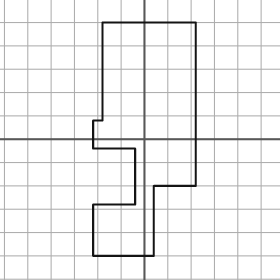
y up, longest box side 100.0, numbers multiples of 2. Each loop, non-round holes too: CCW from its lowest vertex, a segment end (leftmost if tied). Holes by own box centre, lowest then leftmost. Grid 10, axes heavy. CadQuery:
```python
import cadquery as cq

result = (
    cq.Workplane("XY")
    .moveTo(-22.0, -50.0)
    .lineTo(4.0, -50.0)
    .lineTo(4.0, -20.0)
    .lineTo(22.0, -20.0)
    .lineTo(22.0, 50.0)
    .lineTo(-18.0, 50.0)
    .lineTo(-18.0, 8.0)
    .lineTo(-22.0, 8.0)
    .lineTo(-22.0, -4.0)
    .lineTo(-4.0, -4.0)
    .lineTo(-4.0, -28.0)
    .lineTo(-22.0, -28.0)
    .close()
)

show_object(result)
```